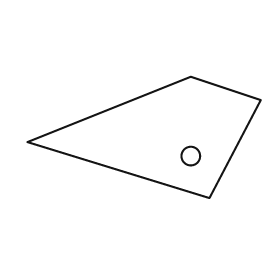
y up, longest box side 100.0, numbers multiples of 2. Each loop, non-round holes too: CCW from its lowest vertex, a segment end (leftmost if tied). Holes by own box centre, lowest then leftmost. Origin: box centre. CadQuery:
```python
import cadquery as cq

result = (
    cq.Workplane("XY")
    .moveTo(28.0, -26.0)
    .lineTo(50.0, 16.0)
    .lineTo(20.0, 26.0)
    .lineTo(-50.0, -2.0)
    .close()
    .moveTo(20.0, -8.0)
    .circle(4.0)
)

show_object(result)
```